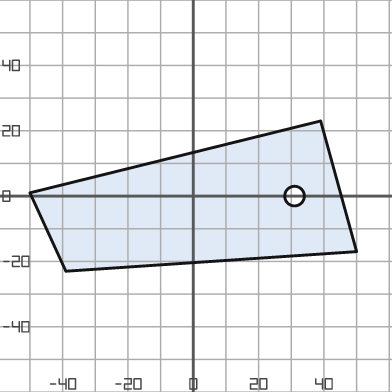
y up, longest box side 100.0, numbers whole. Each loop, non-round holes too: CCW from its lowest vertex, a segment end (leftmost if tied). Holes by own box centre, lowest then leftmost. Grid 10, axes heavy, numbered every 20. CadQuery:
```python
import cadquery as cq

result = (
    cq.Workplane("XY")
    .moveTo(-39.0, -23.0)
    .lineTo(50.0, -17.0)
    .lineTo(39.0, 23.0)
    .lineTo(-50.0, 1.0)
    .close()
    .moveTo(31.0, 0.0)
    .circle(3.0)
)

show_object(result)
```